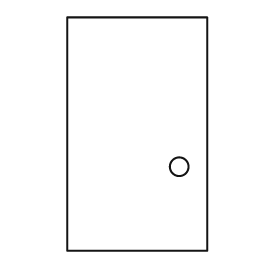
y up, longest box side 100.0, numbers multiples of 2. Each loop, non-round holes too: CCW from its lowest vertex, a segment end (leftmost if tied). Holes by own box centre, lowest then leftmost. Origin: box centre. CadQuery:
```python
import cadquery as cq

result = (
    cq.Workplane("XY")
    .moveTo(-30.0, -50.0)
    .lineTo(30.0, -50.0)
    .lineTo(30.0, 50.0)
    .lineTo(-30.0, 50.0)
    .close()
    .moveTo(18.0, -14.0)
    .circle(4.0)
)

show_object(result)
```